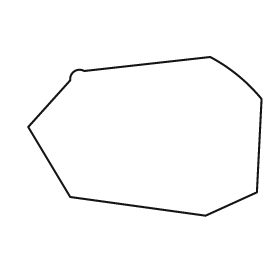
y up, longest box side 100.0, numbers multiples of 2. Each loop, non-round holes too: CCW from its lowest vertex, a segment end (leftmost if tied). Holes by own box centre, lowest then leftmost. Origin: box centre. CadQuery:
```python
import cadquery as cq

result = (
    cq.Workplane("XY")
    .moveTo(26.0, -34.0)
    .lineTo(48.0, -24.0)
    .lineTo(50.0, 16.0)
    .threePointArc((40.0, 26.0), (28.0, 34.0))
    .lineTo(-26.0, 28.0)
    .threePointArc((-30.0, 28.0), (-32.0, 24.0))
    .lineTo(-50.0, 4.0)
    .lineTo(-32.0, -26.0)
    .close()
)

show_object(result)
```